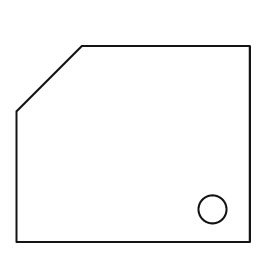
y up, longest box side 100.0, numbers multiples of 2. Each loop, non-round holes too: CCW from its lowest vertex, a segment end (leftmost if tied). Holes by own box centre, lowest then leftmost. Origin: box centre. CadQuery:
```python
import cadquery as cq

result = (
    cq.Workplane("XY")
    .moveTo(-50.0, -42.0)
    .lineTo(50.0, -42.0)
    .lineTo(50.0, 42.0)
    .lineTo(-22.0, 42.0)
    .lineTo(-50.0, 14.0)
    .close()
    .moveTo(34.0, -28.0)
    .circle(6.0)
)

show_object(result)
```